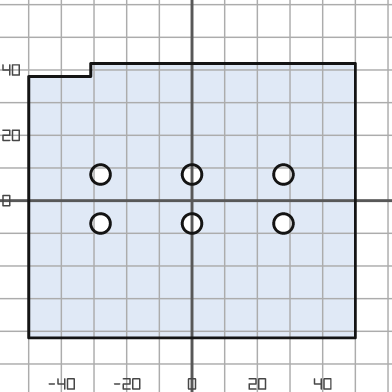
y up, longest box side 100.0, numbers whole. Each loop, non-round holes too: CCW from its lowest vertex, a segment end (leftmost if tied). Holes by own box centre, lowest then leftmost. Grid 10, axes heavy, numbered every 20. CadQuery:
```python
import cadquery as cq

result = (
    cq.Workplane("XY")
    .moveTo(-50.0, -42.0)
    .lineTo(50.0, -42.0)
    .lineTo(50.0, 42.0)
    .lineTo(-31.0, 42.0)
    .lineTo(-31.0, 38.0)
    .lineTo(-50.0, 38.0)
    .close()
    .moveTo(-28.0, -7.0)
    .circle(3.0)
    .moveTo(0.0, -7.0)
    .circle(3.0)
    .moveTo(28.0, -7.0)
    .circle(3.0)
    .moveTo(-28.0, 8.0)
    .circle(3.0)
    .moveTo(0.0, 8.0)
    .circle(3.0)
    .moveTo(28.0, 8.0)
    .circle(3.0)
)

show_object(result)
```